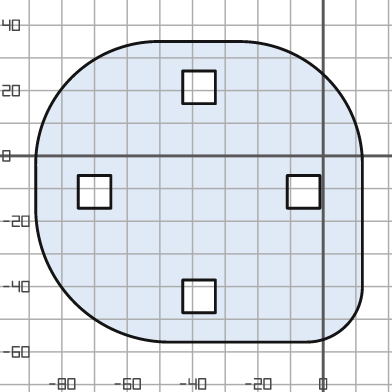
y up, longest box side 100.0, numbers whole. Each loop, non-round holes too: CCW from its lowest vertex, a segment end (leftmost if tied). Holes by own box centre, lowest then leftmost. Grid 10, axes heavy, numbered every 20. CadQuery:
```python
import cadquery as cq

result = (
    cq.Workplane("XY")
    .moveTo(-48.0, -57.0)
    .lineTo(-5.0, -57.0)
    .threePointArc((7.0, -52.0), (12.0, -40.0))
    .lineTo(12.0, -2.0)
    .threePointArc((1.0, 24.0), (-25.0, 35.0))
    .lineTo(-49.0, 35.0)
    .threePointArc((-77.0, 24.0), (-88.0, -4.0))
    .lineTo(-88.0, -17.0)
    .threePointArc((-76.0, -45.0), (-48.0, -57.0))
    .close()
    .moveTo(-43.0, -48.0)
    .lineTo(-33.0, -48.0)
    .lineTo(-33.0, -38.0)
    .lineTo(-43.0, -38.0)
    .close()
    .moveTo(-75.0, -16.0)
    .lineTo(-65.0, -16.0)
    .lineTo(-65.0, -6.0)
    .lineTo(-75.0, -6.0)
    .close()
    .moveTo(-11.0, -16.0)
    .lineTo(-1.0, -16.0)
    .lineTo(-1.0, -6.0)
    .lineTo(-11.0, -6.0)
    .close()
    .moveTo(-43.0, 16.0)
    .lineTo(-33.0, 16.0)
    .lineTo(-33.0, 26.0)
    .lineTo(-43.0, 26.0)
    .close()
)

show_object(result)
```